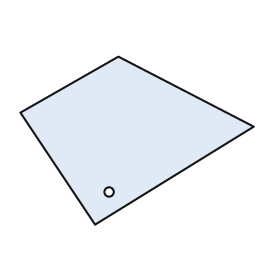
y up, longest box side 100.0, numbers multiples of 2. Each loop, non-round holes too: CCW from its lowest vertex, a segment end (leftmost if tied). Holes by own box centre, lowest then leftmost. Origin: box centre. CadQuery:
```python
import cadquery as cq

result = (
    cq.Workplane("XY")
    .moveTo(-18.0, -36.0)
    .lineTo(50.0, 6.0)
    .lineTo(-8.0, 36.0)
    .lineTo(-50.0, 12.0)
    .close()
    .moveTo(-12.0, -22.0)
    .circle(2.0)
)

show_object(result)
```